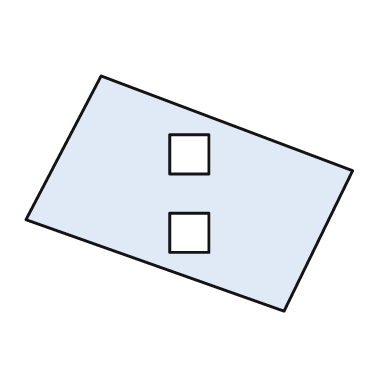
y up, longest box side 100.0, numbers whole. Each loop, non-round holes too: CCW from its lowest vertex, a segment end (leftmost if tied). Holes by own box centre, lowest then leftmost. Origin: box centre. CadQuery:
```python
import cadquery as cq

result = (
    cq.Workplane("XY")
    .moveTo(29.0, -36.0)
    .lineTo(50.0, 7.0)
    .lineTo(-27.0, 36.0)
    .lineTo(-50.0, -8.0)
    .close()
    .moveTo(-6.0, -18.0)
    .lineTo(6.0, -18.0)
    .lineTo(6.0, -6.0)
    .lineTo(-6.0, -6.0)
    .close()
    .moveTo(-6.0, 6.0)
    .lineTo(6.0, 6.0)
    .lineTo(6.0, 18.0)
    .lineTo(-6.0, 18.0)
    .close()
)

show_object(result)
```